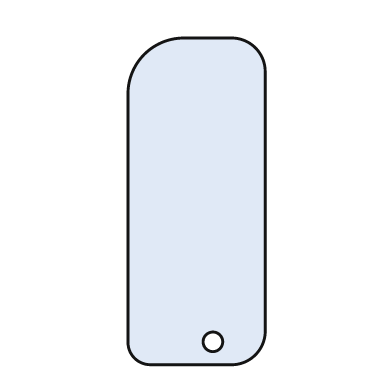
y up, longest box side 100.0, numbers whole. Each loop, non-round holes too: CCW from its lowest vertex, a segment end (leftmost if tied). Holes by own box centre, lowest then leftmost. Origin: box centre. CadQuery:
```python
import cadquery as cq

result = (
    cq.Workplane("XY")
    .moveTo(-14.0, -50.0)
    .lineTo(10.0, -50.0)
    .threePointArc((18.0, -47.0), (21.0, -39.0))
    .lineTo(21.0, 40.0)
    .threePointArc((18.0, 47.0), (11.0, 50.0))
    .lineTo(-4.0, 50.0)
    .threePointArc((-16.0, 45.0), (-21.0, 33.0))
    .lineTo(-21.0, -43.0)
    .threePointArc((-19.0, -48.0), (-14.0, -50.0))
    .close()
    .moveTo(5.0, -43.0)
    .circle(3.0)
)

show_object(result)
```